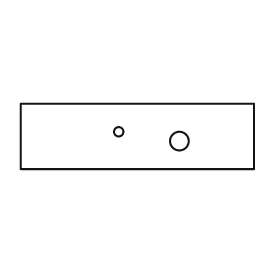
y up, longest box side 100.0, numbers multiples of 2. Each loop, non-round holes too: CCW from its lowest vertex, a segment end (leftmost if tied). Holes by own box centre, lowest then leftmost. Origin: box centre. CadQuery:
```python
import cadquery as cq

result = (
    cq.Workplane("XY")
    .moveTo(-50.0, -14.0)
    .lineTo(50.0, -14.0)
    .lineTo(50.0, 14.0)
    .lineTo(-50.0, 14.0)
    .close()
    .moveTo(18.0, -2.0)
    .circle(4.0)
    .moveTo(-8.0, 2.0)
    .circle(2.0)
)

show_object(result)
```